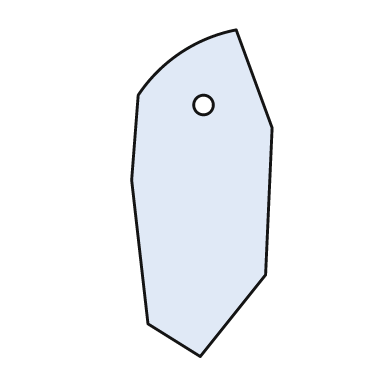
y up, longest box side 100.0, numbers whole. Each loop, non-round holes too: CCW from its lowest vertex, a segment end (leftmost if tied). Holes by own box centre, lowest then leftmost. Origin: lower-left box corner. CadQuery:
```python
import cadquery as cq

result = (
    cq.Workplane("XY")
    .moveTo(21.0, 0.0)
    .lineTo(41.0, 25.0)
    .lineTo(43.0, 70.0)
    .lineTo(32.0, 100.0)
    .threePointArc((15.0, 93.0), (2.0, 80.0))
    .lineTo(0.0, 54.0)
    .lineTo(5.0, 10.0)
    .close()
    .moveTo(22.0, 77.0)
    .circle(3.0)
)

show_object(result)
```